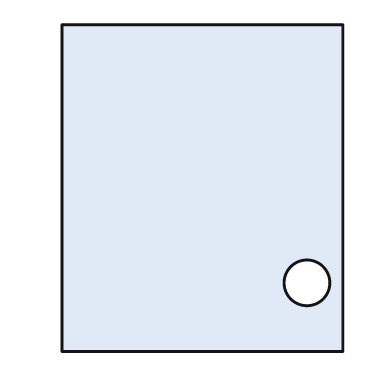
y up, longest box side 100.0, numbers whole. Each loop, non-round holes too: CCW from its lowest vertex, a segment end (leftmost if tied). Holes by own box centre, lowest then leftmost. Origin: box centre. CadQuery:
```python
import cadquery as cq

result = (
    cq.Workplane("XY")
    .moveTo(-43.0, -50.0)
    .lineTo(43.0, -50.0)
    .lineTo(43.0, 50.0)
    .lineTo(-43.0, 50.0)
    .close()
    .moveTo(32.0, -29.0)
    .circle(7.0)
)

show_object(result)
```